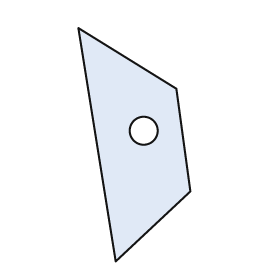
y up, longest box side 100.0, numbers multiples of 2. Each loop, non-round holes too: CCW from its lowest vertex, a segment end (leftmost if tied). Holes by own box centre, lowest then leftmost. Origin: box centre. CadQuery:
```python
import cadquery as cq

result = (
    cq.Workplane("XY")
    .moveTo(-8.0, -50.0)
    .lineTo(24.0, -20.0)
    .lineTo(18.0, 24.0)
    .lineTo(-24.0, 50.0)
    .close()
    .moveTo(4.0, 6.0)
    .circle(6.0)
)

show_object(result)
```